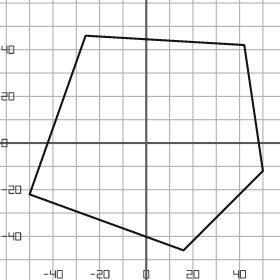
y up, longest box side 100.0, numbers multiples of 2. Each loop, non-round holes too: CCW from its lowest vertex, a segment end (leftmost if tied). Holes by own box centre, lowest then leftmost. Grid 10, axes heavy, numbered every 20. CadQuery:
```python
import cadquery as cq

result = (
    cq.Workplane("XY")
    .moveTo(16.0, -46.0)
    .lineTo(50.0, -12.0)
    .lineTo(42.0, 42.0)
    .lineTo(-26.0, 46.0)
    .lineTo(-50.0, -22.0)
    .close()
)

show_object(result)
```